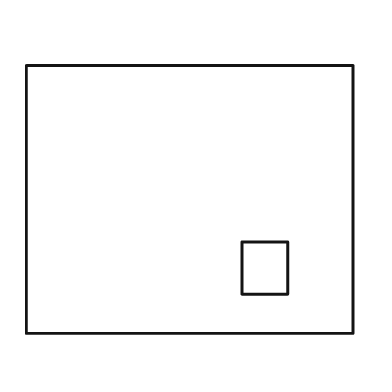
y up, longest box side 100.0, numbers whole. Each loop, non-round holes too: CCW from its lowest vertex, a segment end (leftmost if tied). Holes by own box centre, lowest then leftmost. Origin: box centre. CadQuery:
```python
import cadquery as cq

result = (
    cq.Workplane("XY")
    .moveTo(-50.0, -41.0)
    .lineTo(50.0, -41.0)
    .lineTo(50.0, 41.0)
    .lineTo(-50.0, 41.0)
    .close()
    .moveTo(16.0, -29.0)
    .lineTo(30.0, -29.0)
    .lineTo(30.0, -13.0)
    .lineTo(16.0, -13.0)
    .close()
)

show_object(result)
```